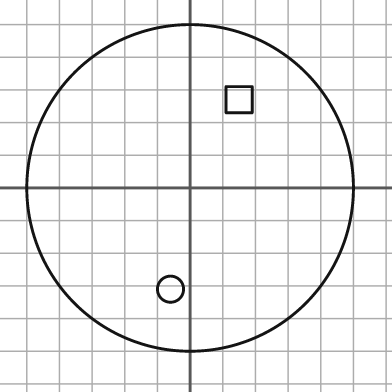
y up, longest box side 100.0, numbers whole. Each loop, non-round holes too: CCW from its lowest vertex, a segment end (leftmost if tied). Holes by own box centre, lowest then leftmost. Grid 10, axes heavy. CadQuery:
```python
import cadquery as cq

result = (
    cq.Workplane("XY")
    .moveTo(0.0, 0.0)
    .circle(50.0)
    .moveTo(-6.0, -31.0)
    .circle(4.0)
    .moveTo(11.0, 23.0)
    .lineTo(19.0, 23.0)
    .lineTo(19.0, 31.0)
    .lineTo(11.0, 31.0)
    .close()
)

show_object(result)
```